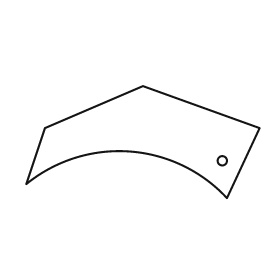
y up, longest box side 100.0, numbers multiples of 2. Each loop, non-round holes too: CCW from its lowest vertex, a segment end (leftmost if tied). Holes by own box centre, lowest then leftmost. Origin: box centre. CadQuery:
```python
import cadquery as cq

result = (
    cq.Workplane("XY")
    .moveTo(36.0, -24.0)
    .lineTo(50.0, 6.0)
    .lineTo(0.0, 24.0)
    .lineTo(-42.0, 6.0)
    .lineTo(-50.0, -18.0)
    .threePointArc((-6.0, -4.0), (36.0, -24.0))
    .close()
    .moveTo(34.0, -8.0)
    .circle(2.0)
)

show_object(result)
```